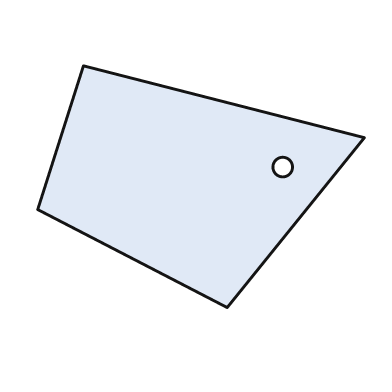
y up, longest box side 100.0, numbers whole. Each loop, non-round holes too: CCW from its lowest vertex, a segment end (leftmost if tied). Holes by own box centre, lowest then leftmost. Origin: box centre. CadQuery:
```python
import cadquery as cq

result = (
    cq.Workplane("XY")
    .moveTo(8.0, -37.0)
    .lineTo(50.0, 15.0)
    .lineTo(-36.0, 37.0)
    .lineTo(-50.0, -7.0)
    .close()
    .moveTo(25.0, 6.0)
    .circle(3.0)
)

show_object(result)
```